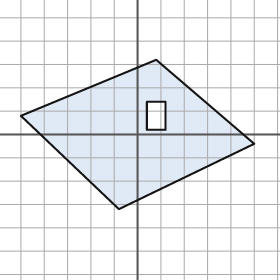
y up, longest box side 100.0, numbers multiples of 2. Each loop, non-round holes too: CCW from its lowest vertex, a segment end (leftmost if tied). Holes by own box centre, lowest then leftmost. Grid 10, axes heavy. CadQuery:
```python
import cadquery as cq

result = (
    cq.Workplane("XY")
    .moveTo(-8.0, -32.0)
    .lineTo(50.0, -4.0)
    .lineTo(8.0, 32.0)
    .lineTo(-50.0, 8.0)
    .close()
    .moveTo(4.0, 2.0)
    .lineTo(12.0, 2.0)
    .lineTo(12.0, 14.0)
    .lineTo(4.0, 14.0)
    .close()
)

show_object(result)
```